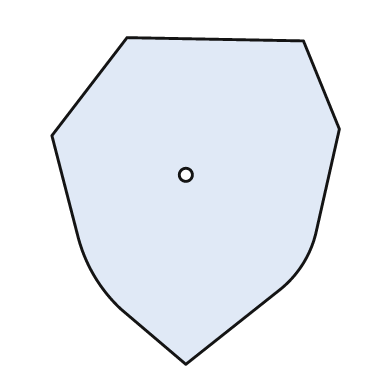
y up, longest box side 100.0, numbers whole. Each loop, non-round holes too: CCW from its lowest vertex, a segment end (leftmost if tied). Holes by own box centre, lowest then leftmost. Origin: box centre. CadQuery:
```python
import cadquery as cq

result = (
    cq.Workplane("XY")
    .moveTo(-3.0, -50.0)
    .lineTo(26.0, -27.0)
    .threePointArc((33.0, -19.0), (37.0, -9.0))
    .lineTo(44.0, 22.0)
    .lineTo(33.0, 49.0)
    .lineTo(-21.0, 50.0)
    .lineTo(-44.0, 20.0)
    .lineTo(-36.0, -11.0)
    .threePointArc((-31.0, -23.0), (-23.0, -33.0))
    .close()
    .moveTo(-3.0, 8.0)
    .circle(2.0)
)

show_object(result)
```